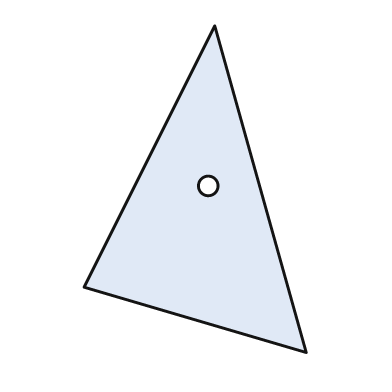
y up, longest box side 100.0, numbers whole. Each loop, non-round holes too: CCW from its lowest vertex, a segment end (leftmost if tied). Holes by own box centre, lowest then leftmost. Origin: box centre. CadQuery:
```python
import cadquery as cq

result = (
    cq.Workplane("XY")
    .moveTo(34.0, -50.0)
    .lineTo(6.0, 50.0)
    .lineTo(-34.0, -30.0)
    .close()
    .moveTo(4.0, 1.0)
    .circle(3.0)
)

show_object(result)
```